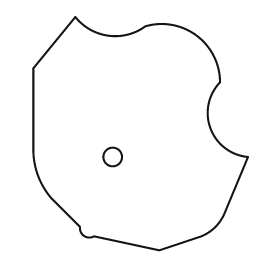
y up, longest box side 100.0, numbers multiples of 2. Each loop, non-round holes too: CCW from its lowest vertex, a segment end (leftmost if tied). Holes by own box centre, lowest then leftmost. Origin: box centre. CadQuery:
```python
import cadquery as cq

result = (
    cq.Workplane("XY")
    .moveTo(8.0, -50.0)
    .lineTo(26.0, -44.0)
    .threePointArc((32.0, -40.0), (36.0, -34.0))
    .lineTo(46.0, -10.0)
    .threePointArc((30.0, 2.0), (34.0, 22.0))
    .threePointArc((24.0, 42.0), (2.0, 46.0))
    .threePointArc((-14.0, 42.0), (-28.0, 50.0))
    .lineTo(-46.0, 28.0)
    .lineTo(-46.0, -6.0)
    .threePointArc((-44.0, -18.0), (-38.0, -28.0))
    .lineTo(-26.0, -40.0)
    .threePointArc((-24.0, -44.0), (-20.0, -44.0))
    .close()
    .moveTo(-12.0, -10.0)
    .circle(4.0)
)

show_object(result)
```